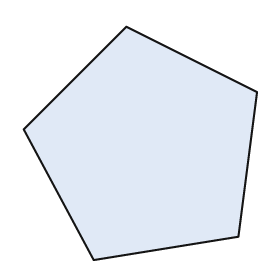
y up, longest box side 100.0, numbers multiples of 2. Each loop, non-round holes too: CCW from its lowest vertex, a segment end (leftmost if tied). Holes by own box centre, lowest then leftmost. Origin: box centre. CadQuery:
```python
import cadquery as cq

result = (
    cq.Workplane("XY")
    .moveTo(-20.0, -50.0)
    .lineTo(42.0, -40.0)
    .lineTo(50.0, 22.0)
    .lineTo(-6.0, 50.0)
    .lineTo(-50.0, 6.0)
    .close()
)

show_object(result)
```